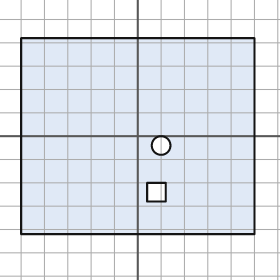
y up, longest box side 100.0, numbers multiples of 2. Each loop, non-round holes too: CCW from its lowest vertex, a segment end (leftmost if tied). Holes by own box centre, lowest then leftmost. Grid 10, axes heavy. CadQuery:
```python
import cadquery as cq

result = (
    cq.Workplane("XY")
    .moveTo(-50.0, -42.0)
    .lineTo(50.0, -42.0)
    .lineTo(50.0, 42.0)
    .lineTo(-50.0, 42.0)
    .close()
    .moveTo(4.0, -28.0)
    .lineTo(12.0, -28.0)
    .lineTo(12.0, -20.0)
    .lineTo(4.0, -20.0)
    .close()
    .moveTo(10.0, -4.0)
    .circle(4.0)
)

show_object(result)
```